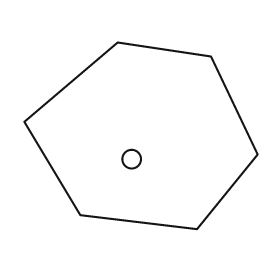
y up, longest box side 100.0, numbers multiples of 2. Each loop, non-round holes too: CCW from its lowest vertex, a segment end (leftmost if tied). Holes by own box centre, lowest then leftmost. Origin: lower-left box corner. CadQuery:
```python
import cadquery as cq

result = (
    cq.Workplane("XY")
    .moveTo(74.0, 0.0)
    .lineTo(100.0, 32.0)
    .lineTo(80.0, 74.0)
    .lineTo(40.0, 80.0)
    .lineTo(0.0, 46.0)
    .lineTo(24.0, 6.0)
    .close()
    .moveTo(46.0, 30.0)
    .circle(4.0)
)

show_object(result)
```